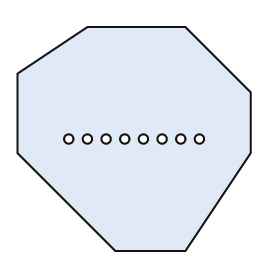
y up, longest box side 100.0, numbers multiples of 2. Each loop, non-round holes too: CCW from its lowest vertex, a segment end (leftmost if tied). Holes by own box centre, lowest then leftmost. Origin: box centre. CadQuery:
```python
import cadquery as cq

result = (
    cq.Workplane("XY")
    .moveTo(-8.0, -48.0)
    .lineTo(22.0, -48.0)
    .lineTo(50.0, -6.0)
    .lineTo(50.0, 20.0)
    .lineTo(22.0, 48.0)
    .lineTo(-20.0, 48.0)
    .lineTo(-50.0, 28.0)
    .lineTo(-50.0, -6.0)
    .close()
    .moveTo(-28.0, 0.0)
    .circle(2.0)
    .moveTo(-20.0, 0.0)
    .circle(2.0)
    .moveTo(-12.0, 0.0)
    .circle(2.0)
    .moveTo(-4.0, 0.0)
    .circle(2.0)
    .moveTo(4.0, 0.0)
    .circle(2.0)
    .moveTo(12.0, 0.0)
    .circle(2.0)
    .moveTo(20.0, 0.0)
    .circle(2.0)
    .moveTo(28.0, 0.0)
    .circle(2.0)
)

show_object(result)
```